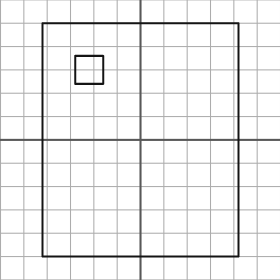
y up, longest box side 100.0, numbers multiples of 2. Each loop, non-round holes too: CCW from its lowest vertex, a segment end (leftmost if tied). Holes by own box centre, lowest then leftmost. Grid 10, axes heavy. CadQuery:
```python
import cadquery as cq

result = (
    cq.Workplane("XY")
    .moveTo(-42.0, -50.0)
    .lineTo(42.0, -50.0)
    .lineTo(42.0, 50.0)
    .lineTo(-42.0, 50.0)
    .close()
    .moveTo(-28.0, 24.0)
    .lineTo(-16.0, 24.0)
    .lineTo(-16.0, 36.0)
    .lineTo(-28.0, 36.0)
    .close()
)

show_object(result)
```